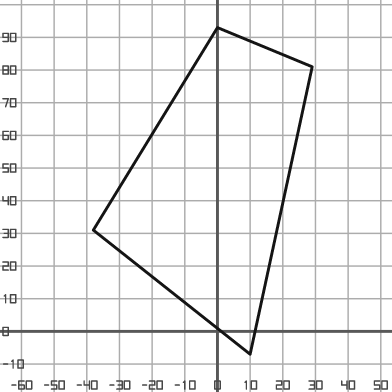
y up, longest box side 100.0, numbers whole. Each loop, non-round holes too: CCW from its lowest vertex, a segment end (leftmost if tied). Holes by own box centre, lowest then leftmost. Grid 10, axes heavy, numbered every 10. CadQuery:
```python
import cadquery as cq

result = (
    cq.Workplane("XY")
    .moveTo(10.0, -7.0)
    .lineTo(29.0, 81.0)
    .lineTo(0.0, 93.0)
    .lineTo(-38.0, 31.0)
    .close()
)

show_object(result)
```